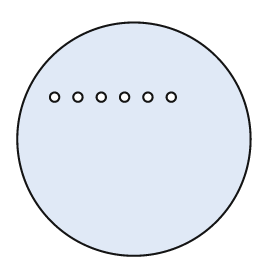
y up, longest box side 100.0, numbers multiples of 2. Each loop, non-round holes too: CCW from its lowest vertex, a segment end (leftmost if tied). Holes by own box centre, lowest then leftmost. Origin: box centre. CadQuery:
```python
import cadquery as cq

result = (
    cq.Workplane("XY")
    .moveTo(0.0, 0.0)
    .circle(50.0)
    .moveTo(-34.0, 18.0)
    .circle(2.0)
    .moveTo(-24.0, 18.0)
    .circle(2.0)
    .moveTo(-14.0, 18.0)
    .circle(2.0)
    .moveTo(-4.0, 18.0)
    .circle(2.0)
    .moveTo(6.0, 18.0)
    .circle(2.0)
    .moveTo(16.0, 18.0)
    .circle(2.0)
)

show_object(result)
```